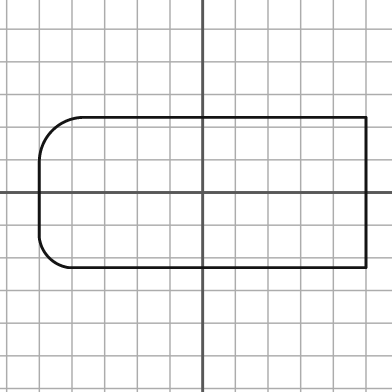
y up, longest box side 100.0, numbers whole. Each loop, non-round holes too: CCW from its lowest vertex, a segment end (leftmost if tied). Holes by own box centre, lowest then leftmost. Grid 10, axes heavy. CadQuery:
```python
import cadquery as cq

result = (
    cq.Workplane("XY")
    .moveTo(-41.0, -23.0)
    .lineTo(50.0, -23.0)
    .lineTo(50.0, 23.0)
    .lineTo(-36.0, 23.0)
    .threePointArc((-46.0, 19.0), (-50.0, 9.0))
    .lineTo(-50.0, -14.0)
    .threePointArc((-47.0, -20.0), (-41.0, -23.0))
    .close()
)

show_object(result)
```